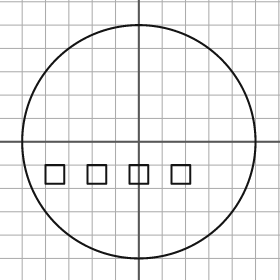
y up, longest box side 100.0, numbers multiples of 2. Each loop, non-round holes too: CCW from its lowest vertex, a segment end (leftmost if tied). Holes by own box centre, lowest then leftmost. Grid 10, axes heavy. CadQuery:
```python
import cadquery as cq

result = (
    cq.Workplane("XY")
    .moveTo(0.0, 0.0)
    .circle(50.0)
    .moveTo(-40.0, -18.0)
    .lineTo(-32.0, -18.0)
    .lineTo(-32.0, -10.0)
    .lineTo(-40.0, -10.0)
    .close()
    .moveTo(-22.0, -18.0)
    .lineTo(-14.0, -18.0)
    .lineTo(-14.0, -10.0)
    .lineTo(-22.0, -10.0)
    .close()
    .moveTo(-4.0, -18.0)
    .lineTo(4.0, -18.0)
    .lineTo(4.0, -10.0)
    .lineTo(-4.0, -10.0)
    .close()
    .moveTo(14.0, -18.0)
    .lineTo(22.0, -18.0)
    .lineTo(22.0, -10.0)
    .lineTo(14.0, -10.0)
    .close()
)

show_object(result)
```